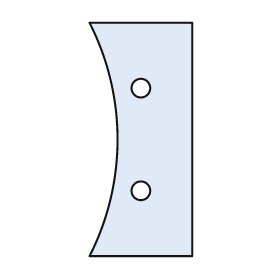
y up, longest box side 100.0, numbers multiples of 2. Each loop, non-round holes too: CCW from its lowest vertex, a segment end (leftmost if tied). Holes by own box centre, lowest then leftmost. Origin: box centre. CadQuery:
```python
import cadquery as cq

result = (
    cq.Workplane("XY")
    .moveTo(-22.0, -50.0)
    .lineTo(22.0, -50.0)
    .lineTo(22.0, 50.0)
    .lineTo(-22.0, 50.0)
    .threePointArc((-10.0, 0.0), (-22.0, -50.0))
    .close()
    .moveTo(0.0, -22.0)
    .circle(4.0)
    .moveTo(0.0, 22.0)
    .circle(4.0)
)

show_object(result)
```